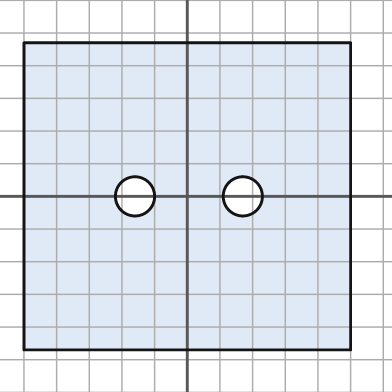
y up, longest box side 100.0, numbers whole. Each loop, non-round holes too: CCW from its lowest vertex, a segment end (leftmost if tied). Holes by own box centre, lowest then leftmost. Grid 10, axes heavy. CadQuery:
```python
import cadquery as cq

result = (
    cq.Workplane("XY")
    .moveTo(-50.0, -47.0)
    .lineTo(50.0, -47.0)
    .lineTo(50.0, 47.0)
    .lineTo(-50.0, 47.0)
    .close()
    .moveTo(-16.0, 0.0)
    .circle(6.0)
    .moveTo(17.0, 0.0)
    .circle(6.0)
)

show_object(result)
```